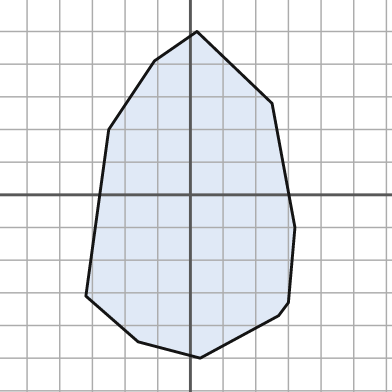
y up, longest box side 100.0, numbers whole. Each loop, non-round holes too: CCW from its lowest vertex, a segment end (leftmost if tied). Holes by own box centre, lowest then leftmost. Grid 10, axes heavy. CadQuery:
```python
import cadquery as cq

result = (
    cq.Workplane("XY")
    .moveTo(3.0, -50.0)
    .lineTo(27.0, -37.0)
    .lineTo(30.0, -33.0)
    .lineTo(32.0, -10.0)
    .lineTo(25.0, 28.0)
    .lineTo(2.0, 50.0)
    .lineTo(-11.0, 41.0)
    .lineTo(-25.0, 20.0)
    .lineTo(-32.0, -31.0)
    .lineTo(-16.0, -45.0)
    .close()
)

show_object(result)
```